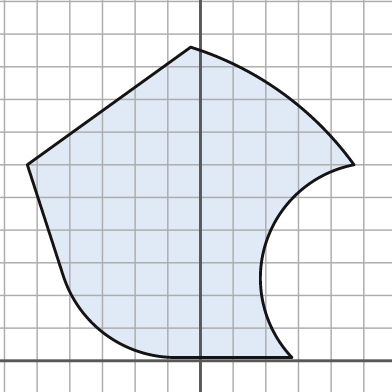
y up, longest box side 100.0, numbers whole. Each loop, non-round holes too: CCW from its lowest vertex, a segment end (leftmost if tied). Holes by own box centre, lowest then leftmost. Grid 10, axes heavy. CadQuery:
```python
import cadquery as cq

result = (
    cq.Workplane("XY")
    .moveTo(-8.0, 1.0)
    .lineTo(28.0, 1.0)
    .threePointArc((20.0, 36.0), (47.0, 60.0))
    .threePointArc((25.0, 82.0), (-3.0, 96.0))
    .lineTo(-53.0, 60.0)
    .lineTo(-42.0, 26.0)
    .threePointArc((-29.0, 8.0), (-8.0, 1.0))
    .close()
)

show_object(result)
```